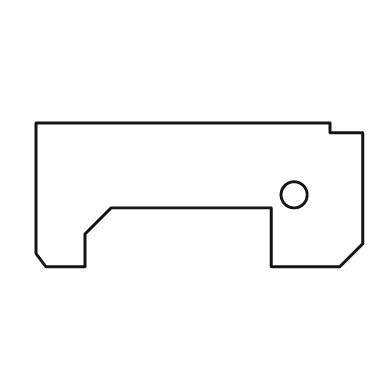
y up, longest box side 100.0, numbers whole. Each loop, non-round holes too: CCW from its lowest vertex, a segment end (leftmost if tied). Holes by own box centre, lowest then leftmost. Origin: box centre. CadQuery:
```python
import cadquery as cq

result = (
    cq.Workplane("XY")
    .moveTo(-47.0, -22.0)
    .lineTo(-35.0, -22.0)
    .lineTo(-35.0, -12.0)
    .lineTo(-27.0, -4.0)
    .lineTo(22.0, -4.0)
    .lineTo(22.0, -22.0)
    .lineTo(43.0, -22.0)
    .lineTo(50.0, -15.0)
    .lineTo(50.0, 19.0)
    .lineTo(40.0, 19.0)
    .lineTo(40.0, 22.0)
    .lineTo(-50.0, 22.0)
    .lineTo(-50.0, -18.0)
    .close()
    .moveTo(29.0, 0.0)
    .circle(4.0)
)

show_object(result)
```